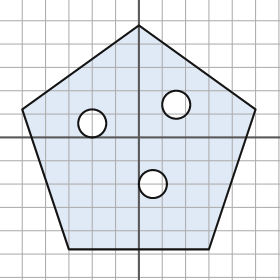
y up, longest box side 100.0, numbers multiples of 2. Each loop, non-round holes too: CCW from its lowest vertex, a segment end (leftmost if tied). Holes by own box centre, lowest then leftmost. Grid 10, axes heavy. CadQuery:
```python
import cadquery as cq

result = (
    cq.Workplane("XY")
    .moveTo(-30.0, -48.0)
    .lineTo(30.0, -48.0)
    .lineTo(50.0, 12.0)
    .lineTo(0.0, 48.0)
    .lineTo(-50.0, 12.0)
    .close()
    .moveTo(6.0, -20.0)
    .circle(6.0)
    .moveTo(-20.0, 6.0)
    .circle(6.0)
    .moveTo(16.0, 14.0)
    .circle(6.0)
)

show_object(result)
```